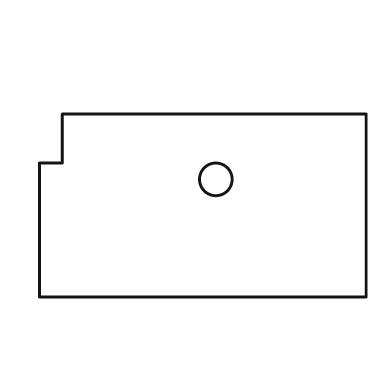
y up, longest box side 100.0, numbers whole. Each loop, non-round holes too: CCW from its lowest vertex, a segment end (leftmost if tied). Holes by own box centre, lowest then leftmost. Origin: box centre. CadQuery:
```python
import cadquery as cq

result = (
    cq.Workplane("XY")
    .moveTo(-50.0, -28.0)
    .lineTo(50.0, -28.0)
    .lineTo(50.0, 28.0)
    .lineTo(-43.0, 28.0)
    .lineTo(-43.0, 13.0)
    .lineTo(-50.0, 13.0)
    .close()
    .moveTo(4.0, 8.0)
    .circle(5.0)
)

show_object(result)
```